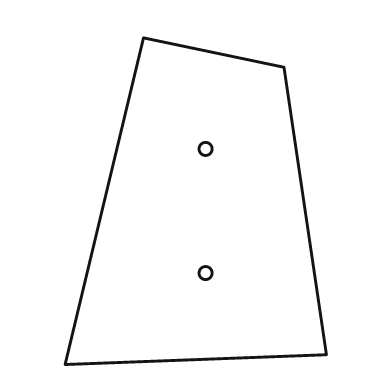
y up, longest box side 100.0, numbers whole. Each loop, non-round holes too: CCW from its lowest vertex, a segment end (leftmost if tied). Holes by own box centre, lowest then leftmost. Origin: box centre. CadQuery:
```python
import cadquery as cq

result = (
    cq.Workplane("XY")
    .moveTo(-40.0, -50.0)
    .lineTo(40.0, -47.0)
    .lineTo(27.0, 41.0)
    .lineTo(-16.0, 50.0)
    .close()
    .moveTo(3.0, -22.0)
    .circle(2.0)
    .moveTo(3.0, 16.0)
    .circle(2.0)
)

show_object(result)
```